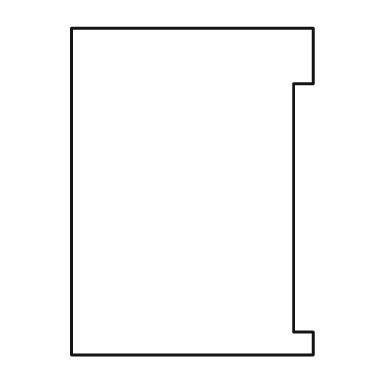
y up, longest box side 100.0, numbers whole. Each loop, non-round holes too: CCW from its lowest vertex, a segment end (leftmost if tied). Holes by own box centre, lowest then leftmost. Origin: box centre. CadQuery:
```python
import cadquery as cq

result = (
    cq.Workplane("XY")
    .moveTo(-37.0, -50.0)
    .lineTo(37.0, -50.0)
    .lineTo(37.0, -43.0)
    .lineTo(31.0, -43.0)
    .lineTo(31.0, 33.0)
    .lineTo(37.0, 33.0)
    .lineTo(37.0, 50.0)
    .lineTo(-37.0, 50.0)
    .close()
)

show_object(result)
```